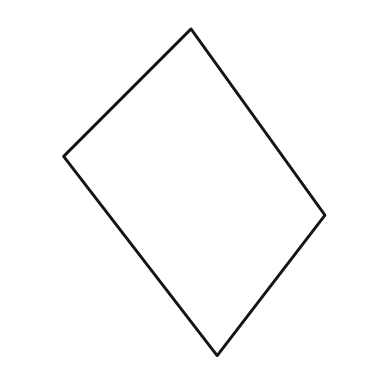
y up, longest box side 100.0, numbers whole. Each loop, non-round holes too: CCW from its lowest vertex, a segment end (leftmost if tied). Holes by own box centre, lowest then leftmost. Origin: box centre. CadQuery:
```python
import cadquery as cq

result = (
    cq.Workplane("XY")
    .moveTo(7.0, -50.0)
    .lineTo(40.0, -7.0)
    .lineTo(-1.0, 50.0)
    .lineTo(-40.0, 11.0)
    .close()
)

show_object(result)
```